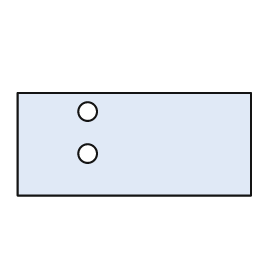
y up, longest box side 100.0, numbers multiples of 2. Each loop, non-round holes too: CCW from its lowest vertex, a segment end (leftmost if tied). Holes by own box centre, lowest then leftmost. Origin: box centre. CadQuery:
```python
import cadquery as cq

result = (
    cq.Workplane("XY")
    .moveTo(-50.0, -22.0)
    .lineTo(50.0, -22.0)
    .lineTo(50.0, 22.0)
    .lineTo(-50.0, 22.0)
    .close()
    .moveTo(-20.0, -4.0)
    .circle(4.0)
    .moveTo(-20.0, 14.0)
    .circle(4.0)
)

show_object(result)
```